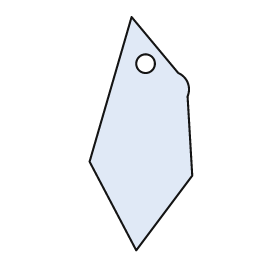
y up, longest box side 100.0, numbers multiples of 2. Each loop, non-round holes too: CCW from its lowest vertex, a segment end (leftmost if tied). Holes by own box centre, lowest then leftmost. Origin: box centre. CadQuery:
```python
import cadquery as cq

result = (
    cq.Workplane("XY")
    .moveTo(-2.0, -50.0)
    .lineTo(22.0, -18.0)
    .lineTo(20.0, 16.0)
    .threePointArc((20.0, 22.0), (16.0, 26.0))
    .lineTo(-4.0, 50.0)
    .lineTo(-22.0, -12.0)
    .close()
    .moveTo(2.0, 30.0)
    .circle(4.0)
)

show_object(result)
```